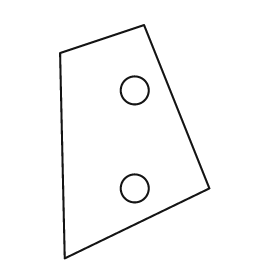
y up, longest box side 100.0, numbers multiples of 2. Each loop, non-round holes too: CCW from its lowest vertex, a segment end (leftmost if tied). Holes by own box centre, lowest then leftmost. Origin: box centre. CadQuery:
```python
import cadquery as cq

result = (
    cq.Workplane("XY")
    .moveTo(-30.0, -50.0)
    .lineTo(32.0, -20.0)
    .lineTo(4.0, 50.0)
    .lineTo(-32.0, 38.0)
    .close()
    .moveTo(0.0, -20.0)
    .circle(6.0)
    .moveTo(0.0, 22.0)
    .circle(6.0)
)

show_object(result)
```